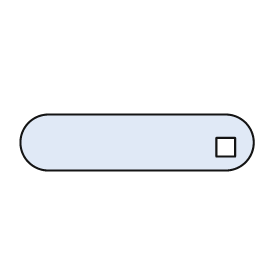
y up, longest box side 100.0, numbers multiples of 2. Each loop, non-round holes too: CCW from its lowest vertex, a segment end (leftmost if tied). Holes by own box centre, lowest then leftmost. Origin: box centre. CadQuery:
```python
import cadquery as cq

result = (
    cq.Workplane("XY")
    .moveTo(-38.0, -12.0)
    .lineTo(38.0, -12.0)
    .threePointArc((50.0, 0.0), (38.0, 12.0))
    .lineTo(-38.0, 12.0)
    .threePointArc((-50.0, 0.0), (-38.0, -12.0))
    .close()
    .moveTo(34.0, -6.0)
    .lineTo(42.0, -6.0)
    .lineTo(42.0, 2.0)
    .lineTo(34.0, 2.0)
    .close()
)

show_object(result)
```